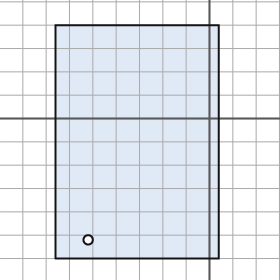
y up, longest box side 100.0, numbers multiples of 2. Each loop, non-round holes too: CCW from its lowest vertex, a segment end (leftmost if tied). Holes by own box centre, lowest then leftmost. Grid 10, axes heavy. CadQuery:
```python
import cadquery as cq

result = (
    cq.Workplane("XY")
    .moveTo(-66.0, -60.0)
    .lineTo(4.0, -60.0)
    .lineTo(4.0, 40.0)
    .lineTo(-66.0, 40.0)
    .close()
    .moveTo(-52.0, -52.0)
    .circle(2.0)
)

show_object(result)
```